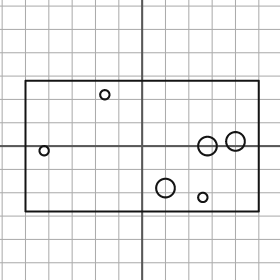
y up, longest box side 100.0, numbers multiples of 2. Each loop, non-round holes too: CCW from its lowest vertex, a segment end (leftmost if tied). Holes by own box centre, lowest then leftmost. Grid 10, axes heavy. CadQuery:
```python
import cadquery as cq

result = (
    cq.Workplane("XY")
    .moveTo(-50.0, -28.0)
    .lineTo(50.0, -28.0)
    .lineTo(50.0, 28.0)
    .lineTo(-50.0, 28.0)
    .close()
    .moveTo(26.0, -22.0)
    .circle(2.0)
    .moveTo(10.0, -18.0)
    .circle(4.0)
    .moveTo(-42.0, -2.0)
    .circle(2.0)
    .moveTo(28.0, 0.0)
    .circle(4.0)
    .moveTo(40.0, 2.0)
    .circle(4.0)
    .moveTo(-16.0, 22.0)
    .circle(2.0)
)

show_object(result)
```